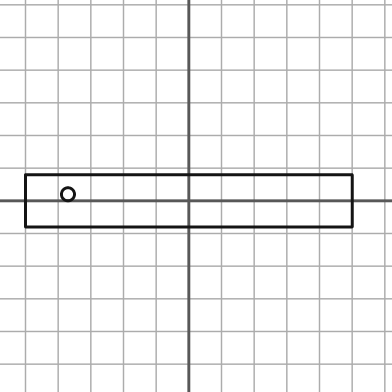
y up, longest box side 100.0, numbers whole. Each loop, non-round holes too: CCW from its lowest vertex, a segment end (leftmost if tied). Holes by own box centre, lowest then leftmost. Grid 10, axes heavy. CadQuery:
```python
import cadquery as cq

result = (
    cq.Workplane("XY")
    .moveTo(-50.0, -8.0)
    .lineTo(50.0, -8.0)
    .lineTo(50.0, 8.0)
    .lineTo(-50.0, 8.0)
    .close()
    .moveTo(-37.0, 2.0)
    .circle(2.0)
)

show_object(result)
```